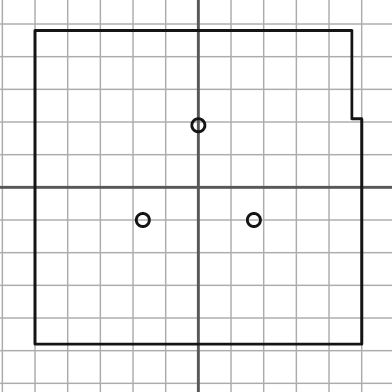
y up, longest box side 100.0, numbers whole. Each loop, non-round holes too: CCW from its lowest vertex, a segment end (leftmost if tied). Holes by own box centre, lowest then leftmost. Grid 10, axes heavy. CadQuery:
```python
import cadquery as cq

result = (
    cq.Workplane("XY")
    .moveTo(-50.0, -48.0)
    .lineTo(50.0, -48.0)
    .lineTo(50.0, 21.0)
    .lineTo(47.0, 21.0)
    .lineTo(47.0, 48.0)
    .lineTo(-50.0, 48.0)
    .close()
    .moveTo(-17.0, -10.0)
    .circle(2.0)
    .moveTo(17.0, -10.0)
    .circle(2.0)
    .moveTo(0.0, 19.0)
    .circle(2.0)
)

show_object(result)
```